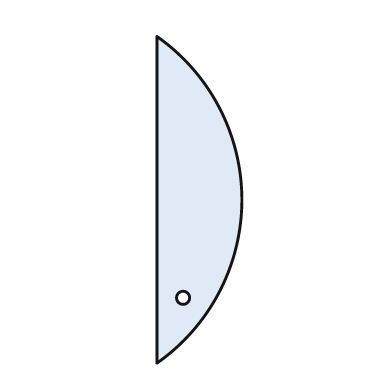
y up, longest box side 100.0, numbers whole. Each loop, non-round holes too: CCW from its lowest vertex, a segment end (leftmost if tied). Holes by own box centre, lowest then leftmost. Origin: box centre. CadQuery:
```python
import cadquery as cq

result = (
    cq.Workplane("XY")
    .moveTo(-13.0, -50.0)
    .threePointArc((13.0, 0.0), (-13.0, 50.0))
    .close()
    .moveTo(-5.0, -30.0)
    .circle(2.0)
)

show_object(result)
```